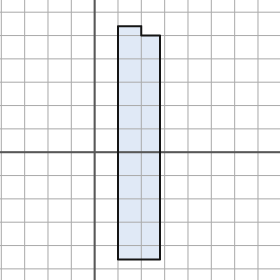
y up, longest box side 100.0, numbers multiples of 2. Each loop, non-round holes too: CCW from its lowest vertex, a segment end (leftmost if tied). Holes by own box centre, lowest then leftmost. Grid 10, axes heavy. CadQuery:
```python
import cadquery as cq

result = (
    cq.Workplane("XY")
    .moveTo(10.0, -46.0)
    .lineTo(28.0, -46.0)
    .lineTo(28.0, 50.0)
    .lineTo(20.0, 50.0)
    .lineTo(20.0, 54.0)
    .lineTo(10.0, 54.0)
    .close()
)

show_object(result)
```